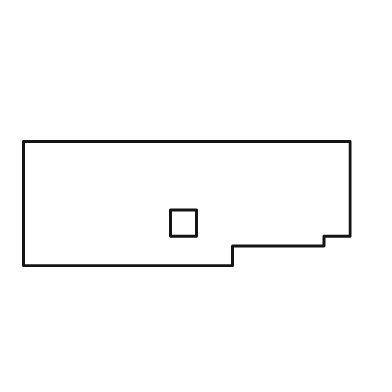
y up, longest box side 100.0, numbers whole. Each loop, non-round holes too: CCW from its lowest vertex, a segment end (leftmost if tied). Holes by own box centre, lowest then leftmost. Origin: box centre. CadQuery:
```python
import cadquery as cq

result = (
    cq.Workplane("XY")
    .moveTo(-50.0, -19.0)
    .lineTo(14.0, -19.0)
    .lineTo(14.0, -13.0)
    .lineTo(42.0, -13.0)
    .lineTo(42.0, -10.0)
    .lineTo(50.0, -10.0)
    .lineTo(50.0, 19.0)
    .lineTo(-50.0, 19.0)
    .close()
    .moveTo(-5.0, -10.0)
    .lineTo(3.0, -10.0)
    .lineTo(3.0, -2.0)
    .lineTo(-5.0, -2.0)
    .close()
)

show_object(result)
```